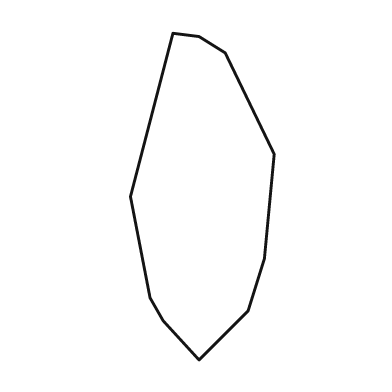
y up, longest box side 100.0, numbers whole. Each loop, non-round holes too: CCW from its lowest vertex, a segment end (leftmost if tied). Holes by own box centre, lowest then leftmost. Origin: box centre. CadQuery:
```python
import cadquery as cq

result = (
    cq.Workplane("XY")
    .moveTo(-1.0, -50.0)
    .lineTo(14.0, -35.0)
    .lineTo(19.0, -19.0)
    .lineTo(22.0, 13.0)
    .lineTo(7.0, 44.0)
    .lineTo(-1.0, 49.0)
    .lineTo(-9.0, 50.0)
    .lineTo(-22.0, 0.0)
    .lineTo(-16.0, -31.0)
    .lineTo(-12.0, -38.0)
    .close()
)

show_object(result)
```